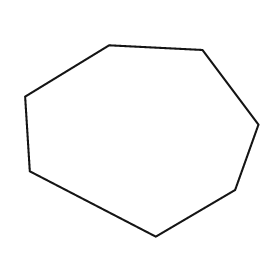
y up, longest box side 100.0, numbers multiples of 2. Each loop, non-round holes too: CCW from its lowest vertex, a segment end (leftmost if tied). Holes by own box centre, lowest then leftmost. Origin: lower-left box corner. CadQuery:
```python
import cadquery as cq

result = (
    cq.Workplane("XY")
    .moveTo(56.0, 0.0)
    .lineTo(90.0, 20.0)
    .lineTo(100.0, 48.0)
    .lineTo(76.0, 80.0)
    .lineTo(36.0, 82.0)
    .lineTo(0.0, 60.0)
    .lineTo(2.0, 28.0)
    .close()
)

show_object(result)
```